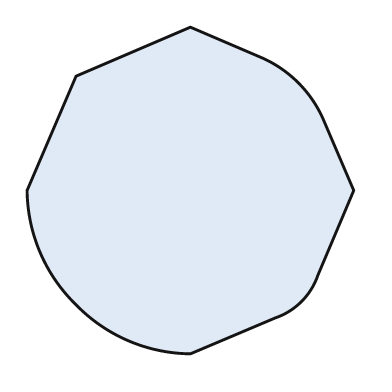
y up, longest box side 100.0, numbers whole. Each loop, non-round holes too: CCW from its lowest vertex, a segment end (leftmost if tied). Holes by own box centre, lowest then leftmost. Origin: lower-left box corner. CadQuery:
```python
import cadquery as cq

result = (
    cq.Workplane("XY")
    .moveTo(50.0, 0.0)
    .lineTo(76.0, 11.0)
    .threePointArc((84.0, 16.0), (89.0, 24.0))
    .lineTo(100.0, 50.0)
    .lineTo(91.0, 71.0)
    .threePointArc((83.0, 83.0), (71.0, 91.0))
    .lineTo(50.0, 100.0)
    .lineTo(15.0, 85.0)
    .lineTo(0.0, 50.0)
    .threePointArc((4.0, 31.0), (15.0, 15.0))
    .threePointArc((31.0, 4.0), (50.0, 0.0))
    .close()
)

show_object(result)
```